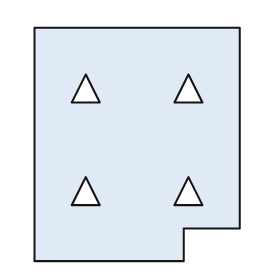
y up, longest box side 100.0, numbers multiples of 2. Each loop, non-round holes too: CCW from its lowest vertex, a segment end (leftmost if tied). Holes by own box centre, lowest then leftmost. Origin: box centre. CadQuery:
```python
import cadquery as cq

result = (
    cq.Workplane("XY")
    .moveTo(-44.0, -50.0)
    .lineTo(20.0, -50.0)
    .lineTo(20.0, -36.0)
    .lineTo(44.0, -36.0)
    .lineTo(44.0, 50.0)
    .lineTo(-44.0, 50.0)
    .close()
    .moveTo(-28.0, -26.0)
    .lineTo(-16.0, -26.0)
    .lineTo(-22.0, -14.0)
    .close()
    .moveTo(16.0, -26.0)
    .lineTo(28.0, -26.0)
    .lineTo(22.0, -14.0)
    .close()
    .moveTo(-28.0, 18.0)
    .lineTo(-16.0, 18.0)
    .lineTo(-22.0, 30.0)
    .close()
    .moveTo(16.0, 18.0)
    .lineTo(28.0, 18.0)
    .lineTo(22.0, 30.0)
    .close()
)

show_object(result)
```